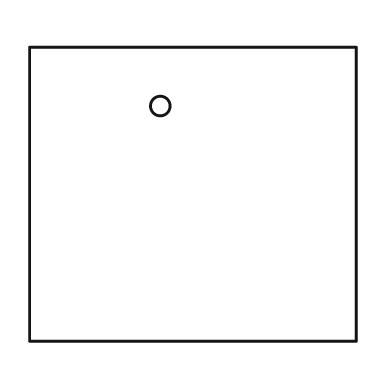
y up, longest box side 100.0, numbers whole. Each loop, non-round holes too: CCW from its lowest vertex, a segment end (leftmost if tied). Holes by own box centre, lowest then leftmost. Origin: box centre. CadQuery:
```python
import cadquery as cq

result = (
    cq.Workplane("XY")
    .moveTo(-50.0, -45.0)
    .lineTo(50.0, -45.0)
    .lineTo(50.0, 45.0)
    .lineTo(-50.0, 45.0)
    .close()
    .moveTo(-10.0, 27.0)
    .circle(3.0)
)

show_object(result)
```